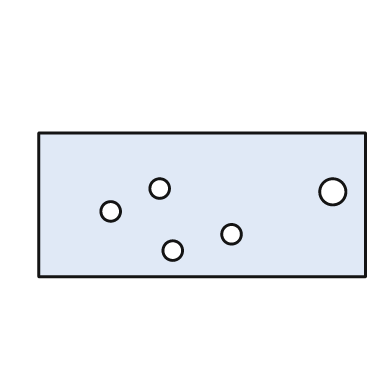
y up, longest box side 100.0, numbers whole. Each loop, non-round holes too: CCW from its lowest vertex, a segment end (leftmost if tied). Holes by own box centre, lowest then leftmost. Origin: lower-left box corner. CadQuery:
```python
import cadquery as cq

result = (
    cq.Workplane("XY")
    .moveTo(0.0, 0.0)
    .lineTo(100.0, 0.0)
    .lineTo(100.0, 44.0)
    .lineTo(0.0, 44.0)
    .close()
    .moveTo(41.0, 8.0)
    .circle(3.0)
    .moveTo(59.0, 13.0)
    .circle(3.0)
    .moveTo(22.0, 20.0)
    .circle(3.0)
    .moveTo(90.0, 26.0)
    .circle(4.0)
    .moveTo(37.0, 27.0)
    .circle(3.0)
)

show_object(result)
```